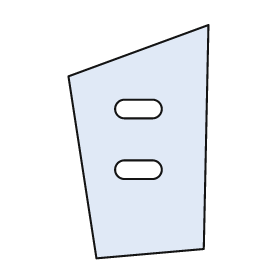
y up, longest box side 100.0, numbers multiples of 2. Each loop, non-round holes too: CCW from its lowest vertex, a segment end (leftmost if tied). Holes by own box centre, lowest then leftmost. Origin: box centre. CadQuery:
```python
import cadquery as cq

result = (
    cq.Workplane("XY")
    .moveTo(-18.0, -50.0)
    .lineTo(28.0, -46.0)
    .lineTo(30.0, 50.0)
    .lineTo(-30.0, 28.0)
    .close()
    .moveTo(-6.0, -16.0)
    .lineTo(6.0, -16.0)
    .threePointArc((10.0, -12.0), (6.0, -8.0))
    .lineTo(-6.0, -8.0)
    .threePointArc((-10.0, -12.0), (-6.0, -16.0))
    .close()
    .moveTo(-6.0, 10.0)
    .lineTo(6.0, 10.0)
    .threePointArc((10.0, 14.0), (6.0, 18.0))
    .lineTo(-6.0, 18.0)
    .threePointArc((-10.0, 14.0), (-6.0, 10.0))
    .close()
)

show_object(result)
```